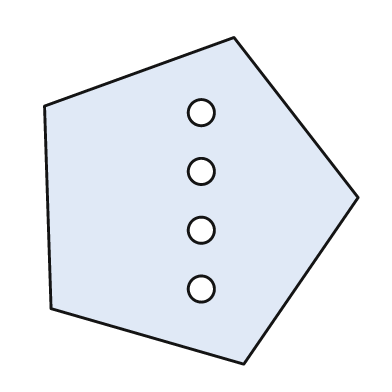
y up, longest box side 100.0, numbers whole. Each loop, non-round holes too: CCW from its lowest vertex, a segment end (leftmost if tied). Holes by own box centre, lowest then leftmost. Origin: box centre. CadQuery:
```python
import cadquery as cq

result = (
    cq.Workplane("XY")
    .moveTo(13.0, -50.0)
    .lineTo(48.0, 1.0)
    .lineTo(10.0, 50.0)
    .lineTo(-48.0, 29.0)
    .lineTo(-46.0, -33.0)
    .close()
    .moveTo(0.0, -27.0)
    .circle(4.0)
    .moveTo(0.0, -9.0)
    .circle(4.0)
    .moveTo(0.0, 9.0)
    .circle(4.0)
    .moveTo(0.0, 27.0)
    .circle(4.0)
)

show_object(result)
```